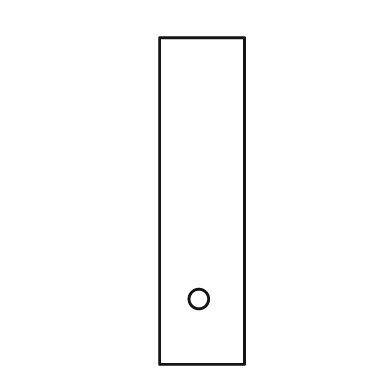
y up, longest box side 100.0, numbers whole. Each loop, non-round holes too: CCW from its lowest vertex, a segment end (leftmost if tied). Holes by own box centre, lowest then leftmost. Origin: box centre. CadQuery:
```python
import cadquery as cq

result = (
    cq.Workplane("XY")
    .moveTo(-13.0, -50.0)
    .lineTo(13.0, -50.0)
    .lineTo(13.0, 50.0)
    .lineTo(-13.0, 50.0)
    .close()
    .moveTo(-1.0, -30.0)
    .circle(3.0)
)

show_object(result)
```